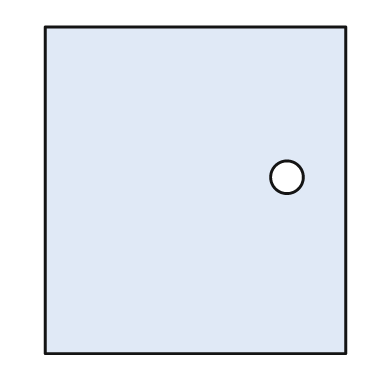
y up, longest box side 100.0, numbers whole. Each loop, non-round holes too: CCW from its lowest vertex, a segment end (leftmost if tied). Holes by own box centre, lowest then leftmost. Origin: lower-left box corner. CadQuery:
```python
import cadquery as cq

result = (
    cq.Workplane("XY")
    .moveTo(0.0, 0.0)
    .lineTo(92.0, 0.0)
    .lineTo(92.0, 100.0)
    .lineTo(0.0, 100.0)
    .close()
    .moveTo(74.0, 54.0)
    .circle(5.0)
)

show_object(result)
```